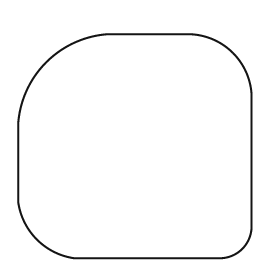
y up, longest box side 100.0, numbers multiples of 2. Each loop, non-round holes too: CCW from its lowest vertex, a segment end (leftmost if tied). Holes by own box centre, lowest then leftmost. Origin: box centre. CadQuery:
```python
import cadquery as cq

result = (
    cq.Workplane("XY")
    .moveTo(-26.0, -48.0)
    .lineTo(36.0, -48.0)
    .threePointArc((46.0, -44.0), (50.0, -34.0))
    .lineTo(50.0, 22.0)
    .threePointArc((42.0, 40.0), (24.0, 48.0))
    .lineTo(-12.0, 48.0)
    .threePointArc((-38.0, 36.0), (-50.0, 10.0))
    .lineTo(-50.0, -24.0)
    .threePointArc((-42.0, -40.0), (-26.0, -48.0))
    .close()
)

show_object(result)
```